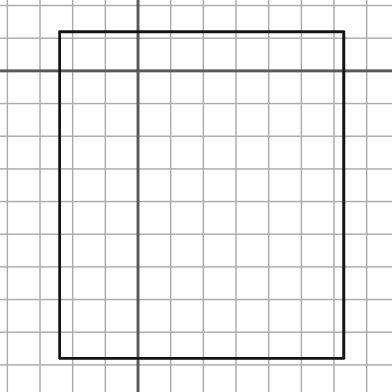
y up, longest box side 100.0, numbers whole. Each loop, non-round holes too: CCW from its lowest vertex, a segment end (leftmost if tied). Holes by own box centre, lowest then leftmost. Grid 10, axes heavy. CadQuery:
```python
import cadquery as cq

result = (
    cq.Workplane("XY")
    .moveTo(-24.0, -88.0)
    .lineTo(63.0, -88.0)
    .lineTo(63.0, 12.0)
    .lineTo(-24.0, 12.0)
    .close()
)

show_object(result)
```